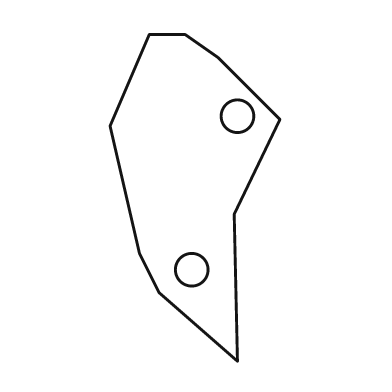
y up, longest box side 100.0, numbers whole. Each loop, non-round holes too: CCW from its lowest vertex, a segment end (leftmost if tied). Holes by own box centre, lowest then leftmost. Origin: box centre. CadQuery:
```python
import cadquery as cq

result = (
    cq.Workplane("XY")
    .moveTo(13.0, -50.0)
    .lineTo(12.0, -5.0)
    .lineTo(26.0, 24.0)
    .lineTo(7.0, 43.0)
    .lineTo(-3.0, 50.0)
    .lineTo(-14.0, 50.0)
    .lineTo(-26.0, 22.0)
    .lineTo(-17.0, -17.0)
    .lineTo(-11.0, -29.0)
    .close()
    .moveTo(-1.0, -22.0)
    .circle(5.0)
    .moveTo(13.0, 25.0)
    .circle(5.0)
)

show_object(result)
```